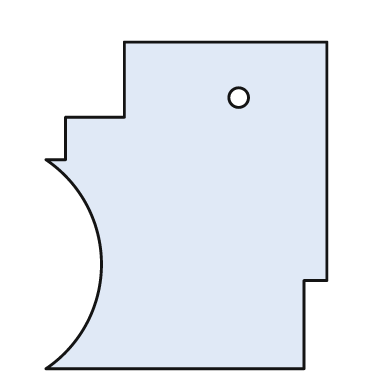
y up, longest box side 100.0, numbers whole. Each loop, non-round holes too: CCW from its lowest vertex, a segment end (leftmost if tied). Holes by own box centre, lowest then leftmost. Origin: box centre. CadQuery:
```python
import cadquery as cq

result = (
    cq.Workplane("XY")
    .moveTo(-43.0, -50.0)
    .lineTo(36.0, -50.0)
    .lineTo(36.0, -23.0)
    .lineTo(43.0, -23.0)
    .lineTo(43.0, 50.0)
    .lineTo(-19.0, 50.0)
    .lineTo(-19.0, 27.0)
    .lineTo(-37.0, 27.0)
    .lineTo(-37.0, 14.0)
    .lineTo(-43.0, 14.0)
    .threePointArc((-26.0, -18.0), (-43.0, -50.0))
    .close()
    .moveTo(16.0, 33.0)
    .circle(3.0)
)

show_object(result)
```